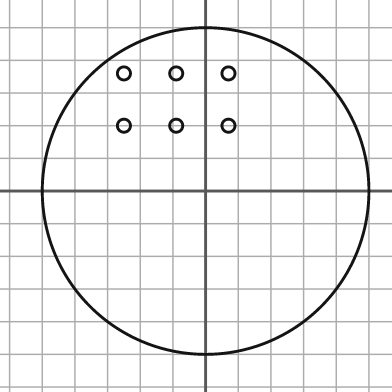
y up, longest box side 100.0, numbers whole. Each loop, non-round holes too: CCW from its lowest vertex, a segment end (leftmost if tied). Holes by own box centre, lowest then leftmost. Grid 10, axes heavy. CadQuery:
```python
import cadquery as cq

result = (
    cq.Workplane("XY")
    .moveTo(0.0, 0.0)
    .circle(50.0)
    .moveTo(-25.0, 20.0)
    .circle(2.0)
    .moveTo(-9.0, 20.0)
    .circle(2.0)
    .moveTo(7.0, 20.0)
    .circle(2.0)
    .moveTo(-25.0, 36.0)
    .circle(2.0)
    .moveTo(-9.0, 36.0)
    .circle(2.0)
    .moveTo(7.0, 36.0)
    .circle(2.0)
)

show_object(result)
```